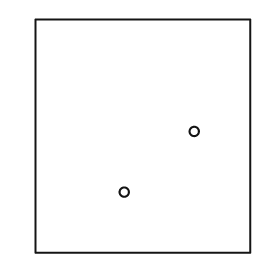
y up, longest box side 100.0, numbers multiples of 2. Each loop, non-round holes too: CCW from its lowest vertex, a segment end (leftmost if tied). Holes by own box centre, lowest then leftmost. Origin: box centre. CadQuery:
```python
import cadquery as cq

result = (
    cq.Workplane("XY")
    .moveTo(-46.0, -50.0)
    .lineTo(46.0, -50.0)
    .lineTo(46.0, 50.0)
    .lineTo(-46.0, 50.0)
    .close()
    .moveTo(-8.0, -24.0)
    .circle(2.0)
    .moveTo(22.0, 2.0)
    .circle(2.0)
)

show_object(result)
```